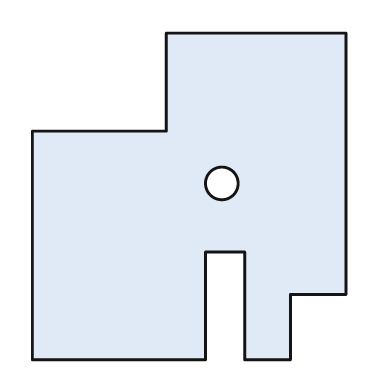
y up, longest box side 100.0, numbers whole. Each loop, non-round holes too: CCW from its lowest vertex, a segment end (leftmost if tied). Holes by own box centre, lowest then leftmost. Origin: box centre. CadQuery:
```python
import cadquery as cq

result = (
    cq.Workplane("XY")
    .moveTo(-48.0, -50.0)
    .lineTo(5.0, -50.0)
    .lineTo(5.0, -17.0)
    .lineTo(17.0, -17.0)
    .lineTo(17.0, -50.0)
    .lineTo(31.0, -50.0)
    .lineTo(31.0, -30.0)
    .lineTo(48.0, -30.0)
    .lineTo(48.0, 50.0)
    .lineTo(-7.0, 50.0)
    .lineTo(-7.0, 20.0)
    .lineTo(-48.0, 20.0)
    .close()
    .moveTo(10.0, 4.0)
    .circle(5.0)
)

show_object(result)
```